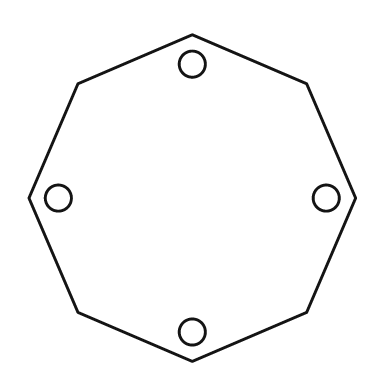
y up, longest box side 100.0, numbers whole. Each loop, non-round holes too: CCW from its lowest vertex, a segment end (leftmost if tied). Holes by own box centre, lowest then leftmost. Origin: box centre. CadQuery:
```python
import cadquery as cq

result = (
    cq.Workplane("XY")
    .moveTo(0.0, -50.0)
    .lineTo(35.0, -35.0)
    .lineTo(50.0, 0.0)
    .lineTo(35.0, 35.0)
    .lineTo(0.0, 50.0)
    .lineTo(-35.0, 35.0)
    .lineTo(-50.0, 0.0)
    .lineTo(-35.0, -35.0)
    .close()
    .moveTo(0.0, -41.0)
    .circle(4.0)
    .moveTo(-41.0, 0.0)
    .circle(4.0)
    .moveTo(41.0, 0.0)
    .circle(4.0)
    .moveTo(0.0, 41.0)
    .circle(4.0)
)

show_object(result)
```